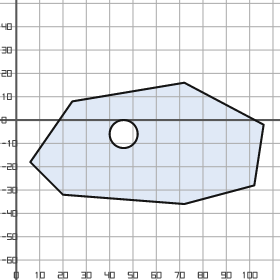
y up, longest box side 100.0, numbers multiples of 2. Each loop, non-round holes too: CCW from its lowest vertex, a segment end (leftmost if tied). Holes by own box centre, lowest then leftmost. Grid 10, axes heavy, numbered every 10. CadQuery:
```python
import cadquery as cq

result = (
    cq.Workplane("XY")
    .moveTo(72.0, -36.0)
    .lineTo(102.0, -28.0)
    .lineTo(106.0, -2.0)
    .lineTo(72.0, 16.0)
    .lineTo(24.0, 8.0)
    .lineTo(6.0, -18.0)
    .lineTo(20.0, -32.0)
    .close()
    .moveTo(46.0, -6.0)
    .circle(6.0)
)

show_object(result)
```